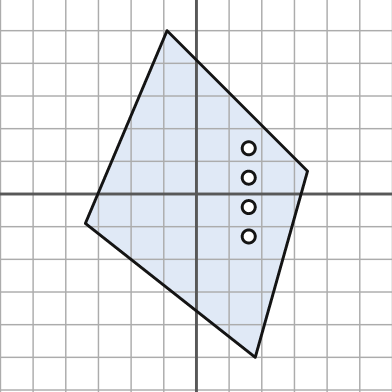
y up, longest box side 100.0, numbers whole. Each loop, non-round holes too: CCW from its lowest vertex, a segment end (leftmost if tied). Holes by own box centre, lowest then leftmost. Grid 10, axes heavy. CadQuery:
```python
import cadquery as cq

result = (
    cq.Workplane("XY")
    .moveTo(18.0, -50.0)
    .lineTo(34.0, 7.0)
    .lineTo(-9.0, 50.0)
    .lineTo(-34.0, -9.0)
    .close()
    .moveTo(16.0, -13.0)
    .circle(2.0)
    .moveTo(16.0, -4.0)
    .circle(2.0)
    .moveTo(16.0, 5.0)
    .circle(2.0)
    .moveTo(16.0, 14.0)
    .circle(2.0)
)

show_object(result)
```